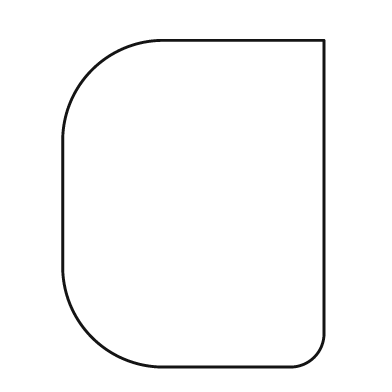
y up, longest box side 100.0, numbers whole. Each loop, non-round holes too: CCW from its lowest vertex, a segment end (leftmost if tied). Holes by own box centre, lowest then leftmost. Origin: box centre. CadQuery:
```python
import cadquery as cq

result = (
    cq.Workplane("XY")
    .moveTo(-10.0, -50.0)
    .lineTo(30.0, -50.0)
    .threePointArc((37.0, -47.0), (40.0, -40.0))
    .lineTo(40.0, 50.0)
    .lineTo(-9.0, 50.0)
    .threePointArc((-31.0, 41.0), (-40.0, 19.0))
    .lineTo(-40.0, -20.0)
    .threePointArc((-31.0, -41.0), (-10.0, -50.0))
    .close()
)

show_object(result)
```